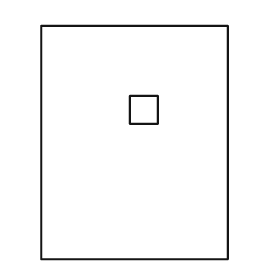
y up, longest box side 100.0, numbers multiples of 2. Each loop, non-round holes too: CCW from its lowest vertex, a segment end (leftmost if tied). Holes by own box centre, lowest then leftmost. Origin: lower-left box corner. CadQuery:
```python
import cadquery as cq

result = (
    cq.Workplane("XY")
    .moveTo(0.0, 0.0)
    .lineTo(80.0, 0.0)
    .lineTo(80.0, 100.0)
    .lineTo(0.0, 100.0)
    .close()
    .moveTo(38.0, 58.0)
    .lineTo(50.0, 58.0)
    .lineTo(50.0, 70.0)
    .lineTo(38.0, 70.0)
    .close()
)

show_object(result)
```